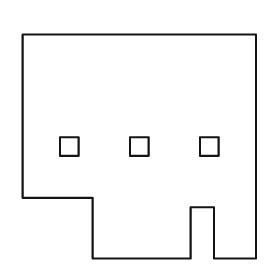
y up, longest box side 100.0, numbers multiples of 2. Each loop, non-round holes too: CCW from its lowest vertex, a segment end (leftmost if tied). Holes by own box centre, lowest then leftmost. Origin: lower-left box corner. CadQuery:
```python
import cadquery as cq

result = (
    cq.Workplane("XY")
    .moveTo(30.0, 0.0)
    .lineTo(72.0, 0.0)
    .lineTo(72.0, 22.0)
    .lineTo(82.0, 22.0)
    .lineTo(82.0, 0.0)
    .lineTo(100.0, 0.0)
    .lineTo(100.0, 96.0)
    .lineTo(0.0, 96.0)
    .lineTo(0.0, 26.0)
    .lineTo(30.0, 26.0)
    .close()
    .moveTo(16.0, 44.0)
    .lineTo(24.0, 44.0)
    .lineTo(24.0, 52.0)
    .lineTo(16.0, 52.0)
    .close()
    .moveTo(46.0, 44.0)
    .lineTo(54.0, 44.0)
    .lineTo(54.0, 52.0)
    .lineTo(46.0, 52.0)
    .close()
    .moveTo(76.0, 44.0)
    .lineTo(84.0, 44.0)
    .lineTo(84.0, 52.0)
    .lineTo(76.0, 52.0)
    .close()
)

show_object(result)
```